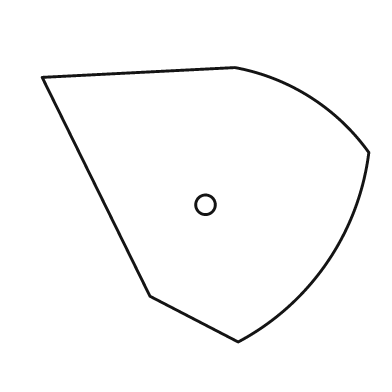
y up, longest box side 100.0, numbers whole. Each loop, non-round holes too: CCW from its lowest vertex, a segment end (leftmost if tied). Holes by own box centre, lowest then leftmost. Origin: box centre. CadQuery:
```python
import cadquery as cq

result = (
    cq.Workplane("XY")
    .moveTo(10.0, -42.0)
    .threePointArc((37.0, -18.0), (50.0, 16.0))
    .threePointArc((32.0, 33.0), (9.0, 42.0))
    .lineTo(-50.0, 39.0)
    .lineTo(-17.0, -28.0)
    .close()
    .moveTo(0.0, 0.0)
    .circle(3.0)
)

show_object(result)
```